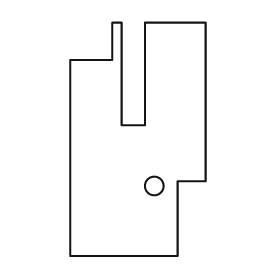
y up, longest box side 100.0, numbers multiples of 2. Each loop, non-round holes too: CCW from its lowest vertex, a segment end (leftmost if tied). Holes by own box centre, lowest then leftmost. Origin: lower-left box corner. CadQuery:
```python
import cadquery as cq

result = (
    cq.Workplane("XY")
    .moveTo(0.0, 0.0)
    .lineTo(46.0, 0.0)
    .lineTo(46.0, 32.0)
    .lineTo(58.0, 32.0)
    .lineTo(58.0, 100.0)
    .lineTo(32.0, 100.0)
    .lineTo(32.0, 56.0)
    .lineTo(22.0, 56.0)
    .lineTo(22.0, 100.0)
    .lineTo(18.0, 100.0)
    .lineTo(18.0, 84.0)
    .lineTo(0.0, 84.0)
    .close()
    .moveTo(36.0, 30.0)
    .circle(4.0)
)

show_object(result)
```